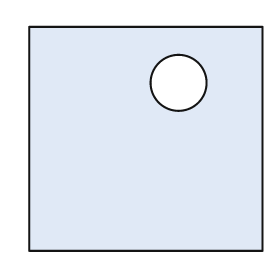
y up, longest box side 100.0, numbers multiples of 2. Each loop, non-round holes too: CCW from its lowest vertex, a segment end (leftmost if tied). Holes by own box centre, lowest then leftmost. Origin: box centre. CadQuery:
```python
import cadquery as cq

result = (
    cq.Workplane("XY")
    .moveTo(-50.0, -48.0)
    .lineTo(50.0, -48.0)
    .lineTo(50.0, 48.0)
    .lineTo(-50.0, 48.0)
    .close()
    .moveTo(14.0, 24.0)
    .circle(12.0)
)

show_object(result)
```